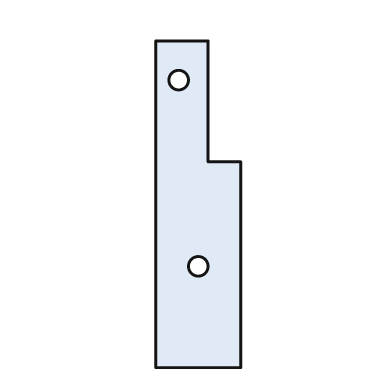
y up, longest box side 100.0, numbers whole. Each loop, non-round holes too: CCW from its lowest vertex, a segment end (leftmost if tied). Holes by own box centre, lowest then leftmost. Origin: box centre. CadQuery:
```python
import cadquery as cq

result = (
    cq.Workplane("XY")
    .moveTo(-13.0, -50.0)
    .lineTo(13.0, -50.0)
    .lineTo(13.0, 13.0)
    .lineTo(3.0, 13.0)
    .lineTo(3.0, 50.0)
    .lineTo(-13.0, 50.0)
    .close()
    .moveTo(0.0, -19.0)
    .circle(3.0)
    .moveTo(-6.0, 38.0)
    .circle(3.0)
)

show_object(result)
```